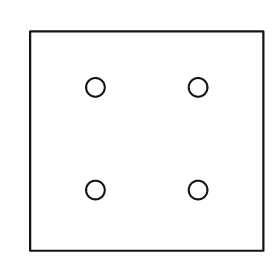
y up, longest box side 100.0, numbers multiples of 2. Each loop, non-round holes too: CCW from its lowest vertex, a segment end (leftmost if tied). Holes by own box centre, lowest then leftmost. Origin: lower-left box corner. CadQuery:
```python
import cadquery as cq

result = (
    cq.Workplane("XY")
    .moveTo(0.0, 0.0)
    .lineTo(100.0, 0.0)
    .lineTo(100.0, 94.0)
    .lineTo(0.0, 94.0)
    .close()
    .moveTo(28.0, 26.0)
    .circle(4.0)
    .moveTo(72.0, 26.0)
    .circle(4.0)
    .moveTo(28.0, 70.0)
    .circle(4.0)
    .moveTo(72.0, 70.0)
    .circle(4.0)
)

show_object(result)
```